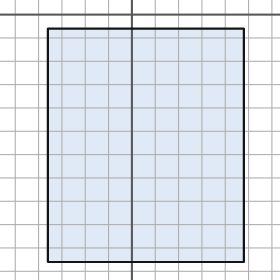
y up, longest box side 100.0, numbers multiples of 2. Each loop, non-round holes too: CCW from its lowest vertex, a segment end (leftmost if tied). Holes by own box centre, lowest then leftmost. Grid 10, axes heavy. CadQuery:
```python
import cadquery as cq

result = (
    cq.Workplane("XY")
    .moveTo(-36.0, -106.0)
    .lineTo(48.0, -106.0)
    .lineTo(48.0, -6.0)
    .lineTo(-36.0, -6.0)
    .close()
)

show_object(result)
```